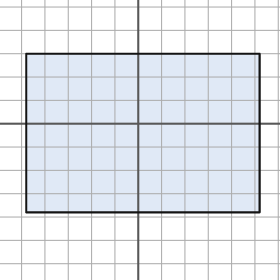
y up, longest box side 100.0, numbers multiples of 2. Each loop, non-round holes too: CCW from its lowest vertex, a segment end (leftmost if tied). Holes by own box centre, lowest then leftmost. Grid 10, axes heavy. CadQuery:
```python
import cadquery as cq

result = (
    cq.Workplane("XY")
    .moveTo(-48.0, -38.0)
    .lineTo(52.0, -38.0)
    .lineTo(52.0, 30.0)
    .lineTo(-48.0, 30.0)
    .close()
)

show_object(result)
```